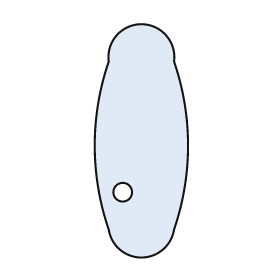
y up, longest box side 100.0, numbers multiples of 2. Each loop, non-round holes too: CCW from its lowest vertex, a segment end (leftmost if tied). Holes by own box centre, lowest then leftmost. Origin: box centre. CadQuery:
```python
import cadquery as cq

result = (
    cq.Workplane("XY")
    .moveTo(-14.0, -38.0)
    .threePointArc((0.0, -50.0), (14.0, -38.0))
    .threePointArc((20.0, -2.0), (14.0, 34.0))
    .threePointArc((0.0, 50.0), (-14.0, 34.0))
    .threePointArc((-20.0, -2.0), (-14.0, -38.0))
    .close()
    .moveTo(-8.0, -22.0)
    .circle(4.0)
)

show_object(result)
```